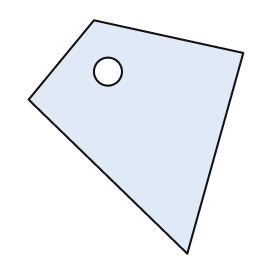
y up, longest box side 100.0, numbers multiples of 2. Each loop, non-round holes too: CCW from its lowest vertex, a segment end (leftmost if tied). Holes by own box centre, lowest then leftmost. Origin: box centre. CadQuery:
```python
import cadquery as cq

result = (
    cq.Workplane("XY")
    .moveTo(22.0, -50.0)
    .lineTo(46.0, 36.0)
    .lineTo(-18.0, 50.0)
    .lineTo(-46.0, 16.0)
    .close()
    .moveTo(-12.0, 28.0)
    .circle(6.0)
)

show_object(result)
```